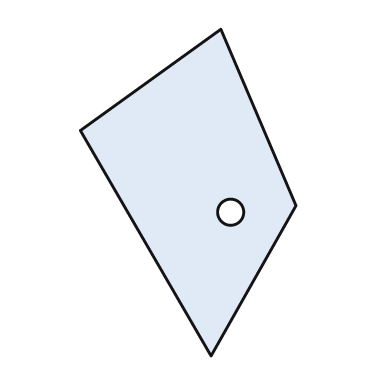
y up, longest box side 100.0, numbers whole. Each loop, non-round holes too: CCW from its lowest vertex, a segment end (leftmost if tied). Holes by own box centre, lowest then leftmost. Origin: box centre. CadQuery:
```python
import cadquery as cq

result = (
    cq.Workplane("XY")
    .moveTo(7.0, -50.0)
    .lineTo(33.0, -4.0)
    .lineTo(10.0, 50.0)
    .lineTo(-33.0, 19.0)
    .close()
    .moveTo(13.0, -6.0)
    .circle(4.0)
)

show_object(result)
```